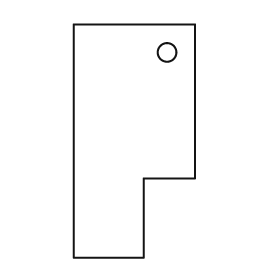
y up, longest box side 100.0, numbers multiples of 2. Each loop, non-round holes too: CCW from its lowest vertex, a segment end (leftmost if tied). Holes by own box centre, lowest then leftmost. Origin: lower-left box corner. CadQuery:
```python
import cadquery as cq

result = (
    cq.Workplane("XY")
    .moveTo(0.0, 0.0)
    .lineTo(30.0, 0.0)
    .lineTo(30.0, 34.0)
    .lineTo(52.0, 34.0)
    .lineTo(52.0, 100.0)
    .lineTo(0.0, 100.0)
    .close()
    .moveTo(40.0, 88.0)
    .circle(4.0)
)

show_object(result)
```